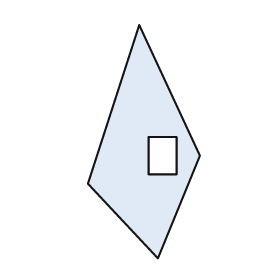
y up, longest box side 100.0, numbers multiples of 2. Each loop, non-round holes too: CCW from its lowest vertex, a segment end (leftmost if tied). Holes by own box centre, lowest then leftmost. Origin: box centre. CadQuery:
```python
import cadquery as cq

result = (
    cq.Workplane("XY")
    .moveTo(6.0, -50.0)
    .lineTo(24.0, -6.0)
    .lineTo(-2.0, 50.0)
    .lineTo(-24.0, -18.0)
    .close()
    .moveTo(2.0, -14.0)
    .lineTo(14.0, -14.0)
    .lineTo(14.0, 2.0)
    .lineTo(2.0, 2.0)
    .close()
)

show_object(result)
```